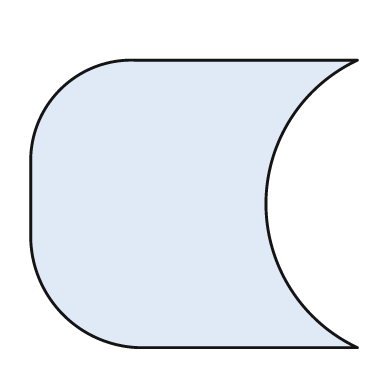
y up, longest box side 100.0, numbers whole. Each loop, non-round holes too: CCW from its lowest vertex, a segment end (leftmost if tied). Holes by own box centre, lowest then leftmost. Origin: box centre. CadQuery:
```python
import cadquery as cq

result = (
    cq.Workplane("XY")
    .moveTo(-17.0, -44.0)
    .lineTo(50.0, -44.0)
    .threePointArc((22.0, 0.0), (50.0, 44.0))
    .lineTo(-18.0, 44.0)
    .threePointArc((-41.0, 35.0), (-50.0, 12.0))
    .lineTo(-50.0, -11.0)
    .threePointArc((-40.0, -34.0), (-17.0, -44.0))
    .close()
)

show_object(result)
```